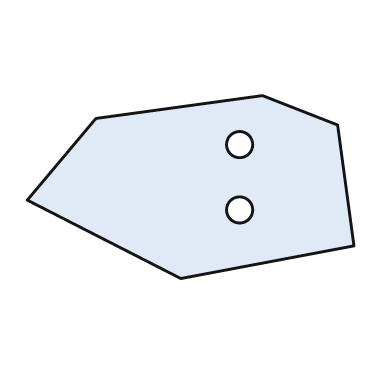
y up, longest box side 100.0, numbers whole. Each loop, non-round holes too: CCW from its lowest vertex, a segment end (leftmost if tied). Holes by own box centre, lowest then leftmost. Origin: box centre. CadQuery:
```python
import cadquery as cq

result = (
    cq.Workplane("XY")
    .moveTo(-3.0, -28.0)
    .lineTo(50.0, -18.0)
    .lineTo(45.0, 19.0)
    .lineTo(22.0, 28.0)
    .lineTo(-29.0, 21.0)
    .lineTo(-50.0, -4.0)
    .close()
    .moveTo(15.0, -7.0)
    .circle(4.0)
    .moveTo(15.0, 13.0)
    .circle(4.0)
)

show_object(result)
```